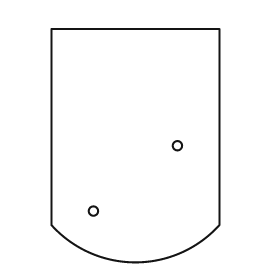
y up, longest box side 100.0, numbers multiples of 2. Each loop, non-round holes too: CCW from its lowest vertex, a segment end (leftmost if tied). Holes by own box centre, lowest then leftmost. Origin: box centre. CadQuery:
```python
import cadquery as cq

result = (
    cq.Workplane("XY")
    .moveTo(-36.0, -34.0)
    .threePointArc((0.0, -50.0), (36.0, -34.0))
    .lineTo(36.0, 50.0)
    .lineTo(-36.0, 50.0)
    .close()
    .moveTo(-18.0, -28.0)
    .circle(2.0)
    .moveTo(18.0, 0.0)
    .circle(2.0)
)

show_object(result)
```